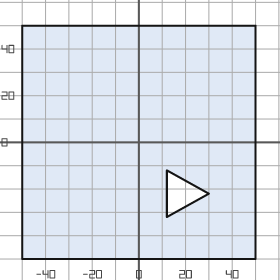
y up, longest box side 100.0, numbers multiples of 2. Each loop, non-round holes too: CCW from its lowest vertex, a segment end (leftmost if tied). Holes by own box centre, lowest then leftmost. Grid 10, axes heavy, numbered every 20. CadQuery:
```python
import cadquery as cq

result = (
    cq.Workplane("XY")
    .moveTo(-50.0, -50.0)
    .lineTo(50.0, -50.0)
    .lineTo(50.0, 50.0)
    .lineTo(-50.0, 50.0)
    .close()
    .moveTo(12.0, -32.0)
    .lineTo(30.0, -22.0)
    .lineTo(12.0, -12.0)
    .close()
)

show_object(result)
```